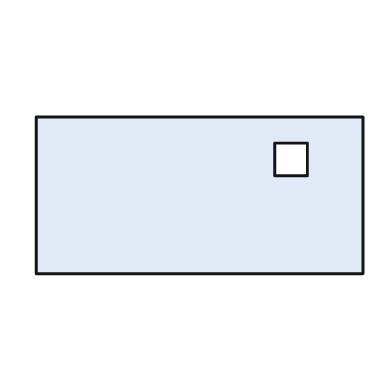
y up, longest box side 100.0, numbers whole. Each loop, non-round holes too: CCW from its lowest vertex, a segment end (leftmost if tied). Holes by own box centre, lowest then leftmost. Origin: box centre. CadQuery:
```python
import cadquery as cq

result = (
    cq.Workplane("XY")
    .moveTo(-50.0, -24.0)
    .lineTo(50.0, -24.0)
    .lineTo(50.0, 24.0)
    .lineTo(-50.0, 24.0)
    .close()
    .moveTo(23.0, 6.0)
    .lineTo(33.0, 6.0)
    .lineTo(33.0, 16.0)
    .lineTo(23.0, 16.0)
    .close()
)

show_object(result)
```